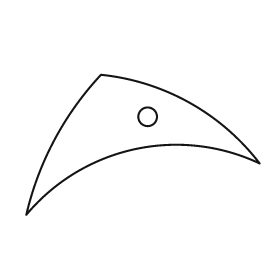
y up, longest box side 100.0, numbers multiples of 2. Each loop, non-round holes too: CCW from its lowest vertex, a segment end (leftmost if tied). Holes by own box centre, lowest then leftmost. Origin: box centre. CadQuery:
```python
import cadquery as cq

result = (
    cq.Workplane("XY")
    .moveTo(-50.0, -30.0)
    .threePointArc((-4.0, -2.0), (50.0, -8.0))
    .threePointArc((20.0, 18.0), (-18.0, 30.0))
    .threePointArc((-38.0, 2.0), (-50.0, -30.0))
    .close()
    .moveTo(2.0, 12.0)
    .circle(4.0)
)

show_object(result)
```